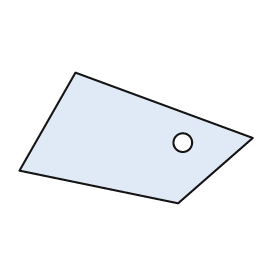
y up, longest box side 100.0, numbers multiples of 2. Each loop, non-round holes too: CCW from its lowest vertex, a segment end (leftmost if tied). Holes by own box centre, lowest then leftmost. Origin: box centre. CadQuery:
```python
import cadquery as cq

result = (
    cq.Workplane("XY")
    .moveTo(18.0, -28.0)
    .lineTo(50.0, 0.0)
    .lineTo(-26.0, 28.0)
    .lineTo(-50.0, -14.0)
    .close()
    .moveTo(20.0, -2.0)
    .circle(4.0)
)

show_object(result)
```